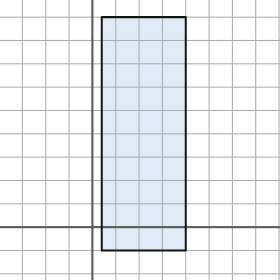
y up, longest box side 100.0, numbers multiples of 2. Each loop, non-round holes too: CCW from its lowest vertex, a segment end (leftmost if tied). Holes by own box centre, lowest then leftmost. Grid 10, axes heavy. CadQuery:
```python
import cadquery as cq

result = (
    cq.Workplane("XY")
    .moveTo(4.0, -10.0)
    .lineTo(40.0, -10.0)
    .lineTo(40.0, 90.0)
    .lineTo(4.0, 90.0)
    .close()
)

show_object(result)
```